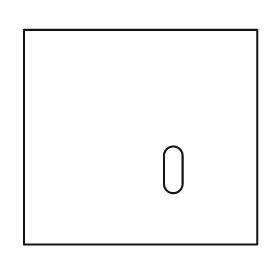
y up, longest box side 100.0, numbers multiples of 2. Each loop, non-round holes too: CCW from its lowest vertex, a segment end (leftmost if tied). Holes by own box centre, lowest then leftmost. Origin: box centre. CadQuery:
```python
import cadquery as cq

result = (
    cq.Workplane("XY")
    .moveTo(-50.0, -46.0)
    .lineTo(50.0, -46.0)
    .lineTo(50.0, 46.0)
    .lineTo(-50.0, 46.0)
    .close()
    .moveTo(10.0, -20.0)
    .threePointArc((14.0, -24.0), (18.0, -20.0))
    .lineTo(18.0, -8.0)
    .threePointArc((14.0, -4.0), (10.0, -8.0))
    .close()
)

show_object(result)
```